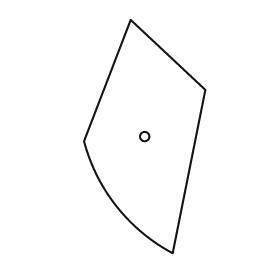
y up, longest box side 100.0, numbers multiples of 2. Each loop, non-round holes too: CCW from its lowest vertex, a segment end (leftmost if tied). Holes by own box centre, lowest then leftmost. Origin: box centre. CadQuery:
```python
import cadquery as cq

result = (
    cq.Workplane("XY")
    .moveTo(12.0, -50.0)
    .lineTo(26.0, 20.0)
    .lineTo(-6.0, 50.0)
    .lineTo(-26.0, -2.0)
    .threePointArc((-12.0, -30.0), (12.0, -50.0))
    .close()
    .moveTo(0.0, 0.0)
    .circle(2.0)
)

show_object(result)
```